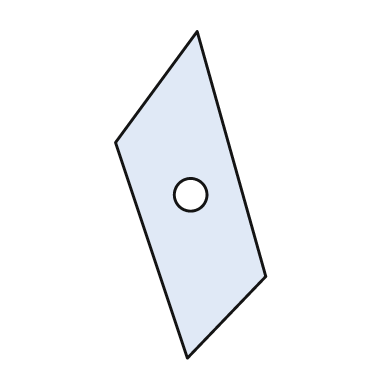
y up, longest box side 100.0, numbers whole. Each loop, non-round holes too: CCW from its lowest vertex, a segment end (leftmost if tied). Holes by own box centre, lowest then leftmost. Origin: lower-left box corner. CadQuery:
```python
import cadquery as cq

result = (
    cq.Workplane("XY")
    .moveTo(22.0, 0.0)
    .lineTo(46.0, 25.0)
    .lineTo(25.0, 100.0)
    .lineTo(0.0, 66.0)
    .close()
    .moveTo(23.0, 50.0)
    .circle(5.0)
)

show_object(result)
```